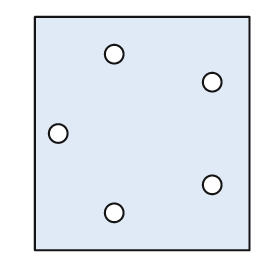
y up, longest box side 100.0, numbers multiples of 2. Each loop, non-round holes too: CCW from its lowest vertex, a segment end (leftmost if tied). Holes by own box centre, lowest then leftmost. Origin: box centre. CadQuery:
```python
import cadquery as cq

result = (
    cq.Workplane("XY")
    .moveTo(-46.0, -50.0)
    .lineTo(46.0, -50.0)
    .lineTo(46.0, 50.0)
    .lineTo(-46.0, 50.0)
    .close()
    .moveTo(-12.0, -34.0)
    .circle(4.0)
    .moveTo(30.0, -22.0)
    .circle(4.0)
    .moveTo(-36.0, 0.0)
    .circle(4.0)
    .moveTo(30.0, 22.0)
    .circle(4.0)
    .moveTo(-12.0, 34.0)
    .circle(4.0)
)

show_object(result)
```